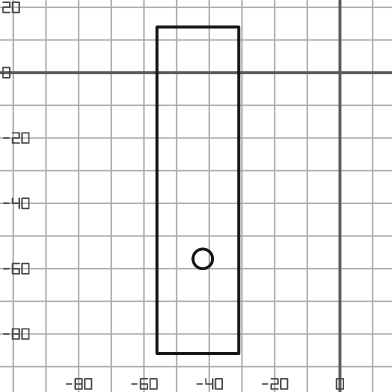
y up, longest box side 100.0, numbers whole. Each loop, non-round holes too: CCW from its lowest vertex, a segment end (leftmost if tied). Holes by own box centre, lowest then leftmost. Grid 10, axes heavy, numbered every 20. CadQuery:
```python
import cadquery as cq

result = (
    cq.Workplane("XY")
    .moveTo(-56.0, -86.0)
    .lineTo(-31.0, -86.0)
    .lineTo(-31.0, 14.0)
    .lineTo(-56.0, 14.0)
    .close()
    .moveTo(-42.0, -57.0)
    .circle(3.0)
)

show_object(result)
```